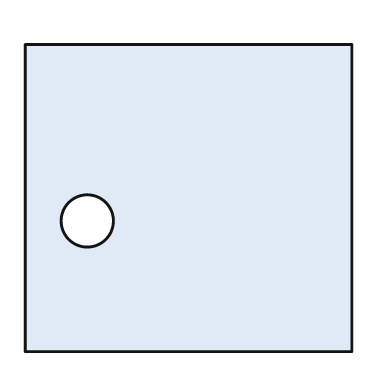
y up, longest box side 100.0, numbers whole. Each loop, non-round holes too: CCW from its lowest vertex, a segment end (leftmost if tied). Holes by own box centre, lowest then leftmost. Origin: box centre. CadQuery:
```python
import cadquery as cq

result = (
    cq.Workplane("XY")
    .moveTo(-50.0, -47.0)
    .lineTo(50.0, -47.0)
    .lineTo(50.0, 47.0)
    .lineTo(-50.0, 47.0)
    .close()
    .moveTo(-31.0, -7.0)
    .circle(8.0)
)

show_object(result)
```